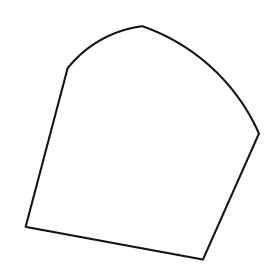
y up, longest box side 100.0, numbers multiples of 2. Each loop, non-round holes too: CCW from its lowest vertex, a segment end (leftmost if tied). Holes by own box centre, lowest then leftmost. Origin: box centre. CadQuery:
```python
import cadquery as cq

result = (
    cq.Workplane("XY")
    .moveTo(26.0, -50.0)
    .lineTo(50.0, 4.0)
    .threePointArc((30.0, 32.0), (0.0, 50.0))
    .threePointArc((-18.0, 44.0), (-32.0, 32.0))
    .lineTo(-50.0, -36.0)
    .close()
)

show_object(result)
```